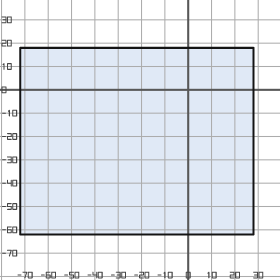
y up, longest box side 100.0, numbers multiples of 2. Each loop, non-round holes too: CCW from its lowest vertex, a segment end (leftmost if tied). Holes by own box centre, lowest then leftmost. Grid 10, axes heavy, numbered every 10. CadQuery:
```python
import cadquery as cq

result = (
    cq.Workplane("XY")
    .moveTo(-72.0, -62.0)
    .lineTo(28.0, -62.0)
    .lineTo(28.0, 18.0)
    .lineTo(-72.0, 18.0)
    .close()
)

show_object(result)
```